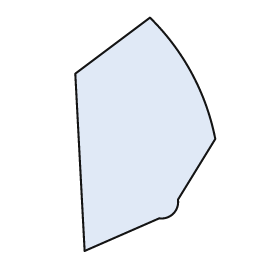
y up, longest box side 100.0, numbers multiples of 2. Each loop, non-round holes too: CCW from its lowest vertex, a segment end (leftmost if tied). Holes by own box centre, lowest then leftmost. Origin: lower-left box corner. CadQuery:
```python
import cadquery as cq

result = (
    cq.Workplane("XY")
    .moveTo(4.0, 0.0)
    .lineTo(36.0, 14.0)
    .threePointArc((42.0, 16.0), (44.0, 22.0))
    .lineTo(60.0, 48.0)
    .threePointArc((50.0, 76.0), (32.0, 100.0))
    .lineTo(0.0, 76.0)
    .close()
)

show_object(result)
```